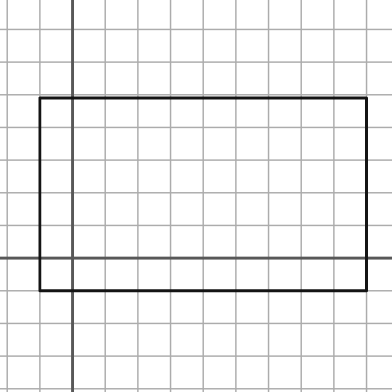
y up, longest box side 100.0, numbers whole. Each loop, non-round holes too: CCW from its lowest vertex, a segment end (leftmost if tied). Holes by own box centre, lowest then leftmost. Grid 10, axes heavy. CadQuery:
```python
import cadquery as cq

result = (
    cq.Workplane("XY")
    .moveTo(-10.0, -10.0)
    .lineTo(90.0, -10.0)
    .lineTo(90.0, 49.0)
    .lineTo(-10.0, 49.0)
    .close()
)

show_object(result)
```